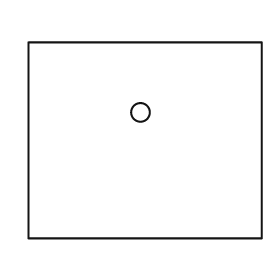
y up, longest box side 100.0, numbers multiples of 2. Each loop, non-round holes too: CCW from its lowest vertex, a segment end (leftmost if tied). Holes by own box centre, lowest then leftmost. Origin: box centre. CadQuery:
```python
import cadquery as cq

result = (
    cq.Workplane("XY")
    .moveTo(-50.0, -42.0)
    .lineTo(50.0, -42.0)
    .lineTo(50.0, 42.0)
    .lineTo(-50.0, 42.0)
    .close()
    .moveTo(-2.0, 12.0)
    .circle(4.0)
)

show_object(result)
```